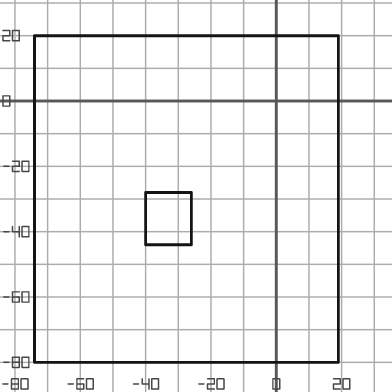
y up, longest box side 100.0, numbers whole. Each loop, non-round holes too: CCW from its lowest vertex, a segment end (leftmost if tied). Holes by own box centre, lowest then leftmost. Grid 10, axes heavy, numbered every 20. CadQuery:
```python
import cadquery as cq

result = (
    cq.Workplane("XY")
    .moveTo(-74.0, -80.0)
    .lineTo(19.0, -80.0)
    .lineTo(19.0, 20.0)
    .lineTo(-74.0, 20.0)
    .close()
    .moveTo(-40.0, -44.0)
    .lineTo(-26.0, -44.0)
    .lineTo(-26.0, -28.0)
    .lineTo(-40.0, -28.0)
    .close()
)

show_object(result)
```